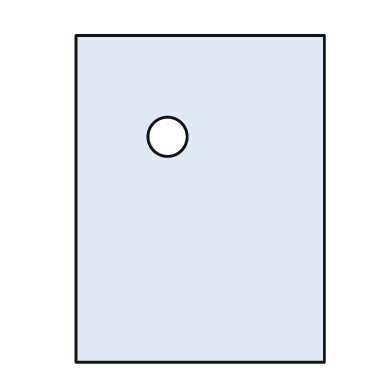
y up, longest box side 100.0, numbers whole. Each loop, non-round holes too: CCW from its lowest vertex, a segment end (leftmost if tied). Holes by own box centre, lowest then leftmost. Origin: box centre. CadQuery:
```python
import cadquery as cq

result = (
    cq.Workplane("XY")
    .moveTo(-38.0, -50.0)
    .lineTo(38.0, -50.0)
    .lineTo(38.0, 50.0)
    .lineTo(-38.0, 50.0)
    .close()
    .moveTo(-10.0, 19.0)
    .circle(6.0)
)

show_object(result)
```